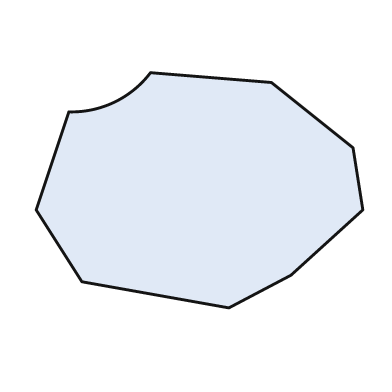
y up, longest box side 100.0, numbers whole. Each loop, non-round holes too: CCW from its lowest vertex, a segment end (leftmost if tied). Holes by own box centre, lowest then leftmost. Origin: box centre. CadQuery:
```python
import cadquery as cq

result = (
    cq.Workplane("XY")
    .moveTo(9.0, -36.0)
    .lineTo(28.0, -26.0)
    .lineTo(50.0, -6.0)
    .lineTo(47.0, 13.0)
    .lineTo(22.0, 33.0)
    .lineTo(-15.0, 36.0)
    .threePointArc((-26.0, 27.0), (-40.0, 24.0))
    .lineTo(-50.0, -6.0)
    .lineTo(-36.0, -28.0)
    .close()
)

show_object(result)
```